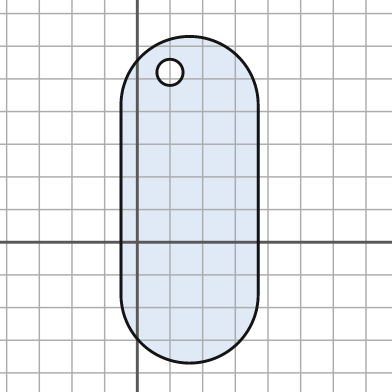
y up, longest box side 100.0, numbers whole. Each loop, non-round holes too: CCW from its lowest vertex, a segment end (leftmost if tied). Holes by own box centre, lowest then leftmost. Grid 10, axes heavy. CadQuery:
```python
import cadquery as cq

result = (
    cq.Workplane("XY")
    .moveTo(-5.0, -16.0)
    .threePointArc((16.0, -37.0), (37.0, -16.0))
    .lineTo(37.0, 42.0)
    .threePointArc((16.0, 63.0), (-5.0, 42.0))
    .close()
    .moveTo(10.0, 52.0)
    .circle(4.0)
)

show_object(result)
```